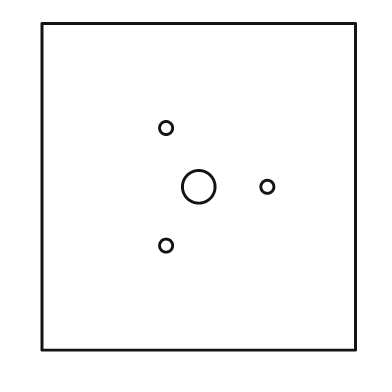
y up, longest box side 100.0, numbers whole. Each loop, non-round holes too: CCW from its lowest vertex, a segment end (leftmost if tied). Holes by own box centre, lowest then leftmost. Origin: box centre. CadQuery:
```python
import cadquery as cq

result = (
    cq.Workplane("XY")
    .moveTo(-48.0, -50.0)
    .lineTo(48.0, -50.0)
    .lineTo(48.0, 50.0)
    .lineTo(-48.0, 50.0)
    .close()
    .moveTo(-10.0, -18.0)
    .circle(2.0)
    .moveTo(0.0, 0.0)
    .circle(5.0)
    .moveTo(21.0, 0.0)
    .circle(2.0)
    .moveTo(-10.0, 18.0)
    .circle(2.0)
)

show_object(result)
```